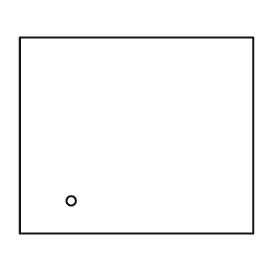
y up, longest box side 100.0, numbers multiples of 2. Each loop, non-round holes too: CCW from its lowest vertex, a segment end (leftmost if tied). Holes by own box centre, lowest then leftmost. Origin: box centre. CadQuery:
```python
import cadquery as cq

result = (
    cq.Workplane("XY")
    .moveTo(-50.0, -42.0)
    .lineTo(50.0, -42.0)
    .lineTo(50.0, 42.0)
    .lineTo(-50.0, 42.0)
    .close()
    .moveTo(-28.0, -28.0)
    .circle(2.0)
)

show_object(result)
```